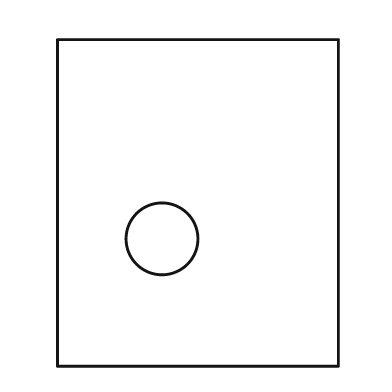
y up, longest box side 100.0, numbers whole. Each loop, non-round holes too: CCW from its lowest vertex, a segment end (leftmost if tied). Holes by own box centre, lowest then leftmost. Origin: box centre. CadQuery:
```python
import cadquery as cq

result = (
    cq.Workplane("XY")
    .moveTo(-43.0, -50.0)
    .lineTo(43.0, -50.0)
    .lineTo(43.0, 50.0)
    .lineTo(-43.0, 50.0)
    .close()
    .moveTo(-11.0, -11.0)
    .circle(11.0)
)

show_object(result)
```